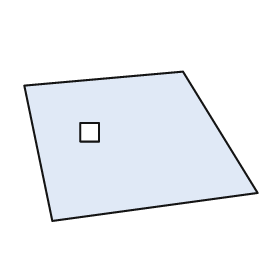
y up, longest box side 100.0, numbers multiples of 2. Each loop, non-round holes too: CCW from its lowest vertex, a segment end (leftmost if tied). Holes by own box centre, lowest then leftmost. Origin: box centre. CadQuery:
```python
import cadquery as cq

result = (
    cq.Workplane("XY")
    .moveTo(-38.0, -32.0)
    .lineTo(50.0, -20.0)
    .lineTo(18.0, 32.0)
    .lineTo(-50.0, 26.0)
    .close()
    .moveTo(-26.0, 2.0)
    .lineTo(-18.0, 2.0)
    .lineTo(-18.0, 10.0)
    .lineTo(-26.0, 10.0)
    .close()
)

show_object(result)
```